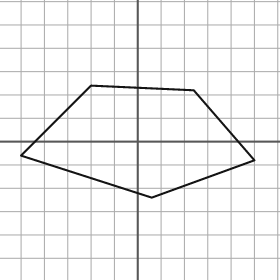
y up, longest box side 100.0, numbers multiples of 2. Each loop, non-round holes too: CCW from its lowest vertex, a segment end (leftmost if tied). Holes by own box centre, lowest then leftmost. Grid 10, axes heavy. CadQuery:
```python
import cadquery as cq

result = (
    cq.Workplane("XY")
    .moveTo(6.0, -24.0)
    .lineTo(50.0, -8.0)
    .lineTo(24.0, 22.0)
    .lineTo(-20.0, 24.0)
    .lineTo(-50.0, -6.0)
    .close()
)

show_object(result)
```